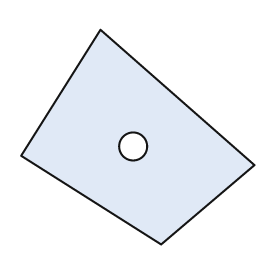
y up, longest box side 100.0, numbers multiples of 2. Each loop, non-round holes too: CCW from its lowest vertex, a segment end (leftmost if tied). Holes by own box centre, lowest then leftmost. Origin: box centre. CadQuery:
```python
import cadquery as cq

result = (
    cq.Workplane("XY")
    .moveTo(10.0, -46.0)
    .lineTo(50.0, -12.0)
    .lineTo(-16.0, 46.0)
    .lineTo(-50.0, -8.0)
    .close()
    .moveTo(-2.0, -4.0)
    .circle(6.0)
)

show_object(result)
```